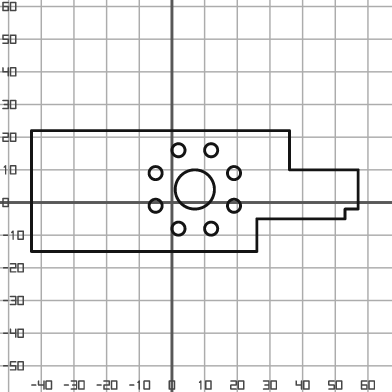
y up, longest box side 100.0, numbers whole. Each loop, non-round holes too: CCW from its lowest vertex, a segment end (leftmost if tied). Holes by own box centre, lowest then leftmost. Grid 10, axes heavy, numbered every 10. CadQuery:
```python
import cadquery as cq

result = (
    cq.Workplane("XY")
    .moveTo(-43.0, -15.0)
    .lineTo(26.0, -15.0)
    .lineTo(26.0, -5.0)
    .lineTo(53.0, -5.0)
    .lineTo(53.0, -2.0)
    .lineTo(57.0, -2.0)
    .lineTo(57.0, 10.0)
    .lineTo(36.0, 10.0)
    .lineTo(36.0, 22.0)
    .lineTo(-43.0, 22.0)
    .close()
    .moveTo(2.0, -8.0)
    .circle(2.0)
    .moveTo(12.0, -8.0)
    .circle(2.0)
    .moveTo(-5.0, -1.0)
    .circle(2.0)
    .moveTo(19.0, -1.0)
    .circle(2.0)
    .moveTo(7.0, 4.0)
    .circle(6.0)
    .moveTo(-5.0, 9.0)
    .circle(2.0)
    .moveTo(19.0, 9.0)
    .circle(2.0)
    .moveTo(2.0, 16.0)
    .circle(2.0)
    .moveTo(12.0, 16.0)
    .circle(2.0)
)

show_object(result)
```